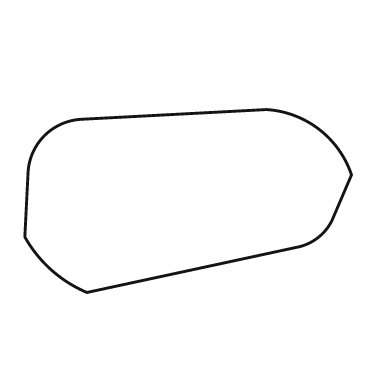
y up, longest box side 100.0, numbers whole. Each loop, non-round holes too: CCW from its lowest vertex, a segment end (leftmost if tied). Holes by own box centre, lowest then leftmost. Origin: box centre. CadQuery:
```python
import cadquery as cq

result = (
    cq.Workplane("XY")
    .moveTo(-31.0, -28.0)
    .lineTo(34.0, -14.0)
    .threePointArc((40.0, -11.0), (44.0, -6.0))
    .lineTo(50.0, 8.0)
    .threePointArc((40.0, 22.0), (24.0, 28.0))
    .lineTo(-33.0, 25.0)
    .threePointArc((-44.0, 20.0), (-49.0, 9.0))
    .lineTo(-50.0, -11.0)
    .threePointArc((-42.0, -21.0), (-31.0, -28.0))
    .close()
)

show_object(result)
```